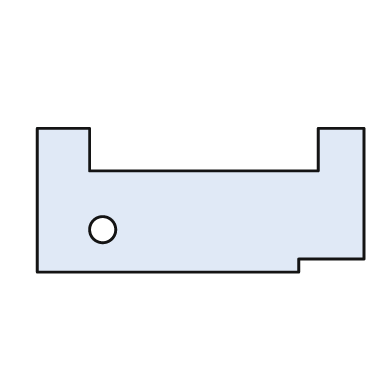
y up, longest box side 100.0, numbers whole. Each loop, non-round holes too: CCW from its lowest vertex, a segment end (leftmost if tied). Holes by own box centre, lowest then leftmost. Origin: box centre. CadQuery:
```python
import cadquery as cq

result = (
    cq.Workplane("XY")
    .moveTo(-50.0, -22.0)
    .lineTo(30.0, -22.0)
    .lineTo(30.0, -18.0)
    .lineTo(50.0, -18.0)
    .lineTo(50.0, 22.0)
    .lineTo(36.0, 22.0)
    .lineTo(36.0, 9.0)
    .lineTo(-34.0, 9.0)
    .lineTo(-34.0, 22.0)
    .lineTo(-50.0, 22.0)
    .close()
    .moveTo(-30.0, -9.0)
    .circle(4.0)
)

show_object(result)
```